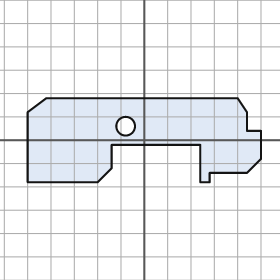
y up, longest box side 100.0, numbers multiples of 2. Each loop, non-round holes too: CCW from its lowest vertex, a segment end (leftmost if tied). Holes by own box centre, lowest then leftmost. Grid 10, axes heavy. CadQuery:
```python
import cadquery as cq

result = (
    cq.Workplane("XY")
    .moveTo(-50.0, -18.0)
    .lineTo(-20.0, -18.0)
    .lineTo(-14.0, -12.0)
    .lineTo(-14.0, -2.0)
    .lineTo(24.0, -2.0)
    .lineTo(24.0, -18.0)
    .lineTo(28.0, -18.0)
    .lineTo(28.0, -14.0)
    .lineTo(44.0, -14.0)
    .lineTo(50.0, -8.0)
    .lineTo(50.0, 4.0)
    .lineTo(44.0, 4.0)
    .lineTo(44.0, 12.0)
    .lineTo(40.0, 18.0)
    .lineTo(-42.0, 18.0)
    .lineTo(-50.0, 12.0)
    .close()
    .moveTo(-8.0, 6.0)
    .circle(4.0)
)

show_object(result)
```